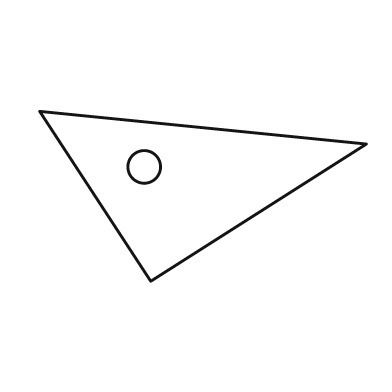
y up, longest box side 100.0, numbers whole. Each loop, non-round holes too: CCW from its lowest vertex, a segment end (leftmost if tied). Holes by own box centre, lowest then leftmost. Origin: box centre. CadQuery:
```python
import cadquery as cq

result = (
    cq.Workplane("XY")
    .moveTo(-16.0, -26.0)
    .lineTo(50.0, 16.0)
    .lineTo(-50.0, 26.0)
    .close()
    .moveTo(-18.0, 9.0)
    .circle(5.0)
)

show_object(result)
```